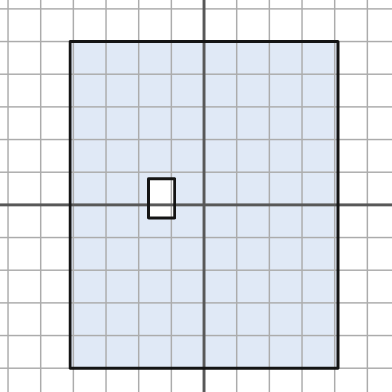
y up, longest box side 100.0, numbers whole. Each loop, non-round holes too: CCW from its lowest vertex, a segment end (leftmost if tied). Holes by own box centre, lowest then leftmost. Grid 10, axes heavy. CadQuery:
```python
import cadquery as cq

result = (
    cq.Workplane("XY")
    .moveTo(-41.0, -50.0)
    .lineTo(41.0, -50.0)
    .lineTo(41.0, 50.0)
    .lineTo(-41.0, 50.0)
    .close()
    .moveTo(-17.0, -4.0)
    .lineTo(-9.0, -4.0)
    .lineTo(-9.0, 8.0)
    .lineTo(-17.0, 8.0)
    .close()
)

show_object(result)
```